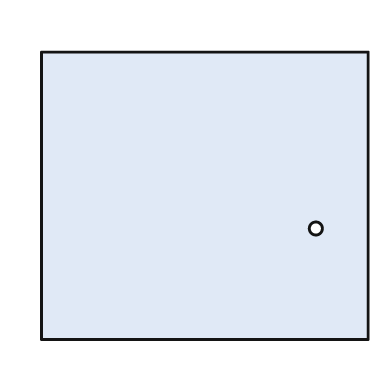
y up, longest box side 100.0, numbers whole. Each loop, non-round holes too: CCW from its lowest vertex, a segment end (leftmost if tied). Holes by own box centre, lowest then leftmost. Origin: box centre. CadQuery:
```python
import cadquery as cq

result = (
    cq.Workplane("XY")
    .moveTo(-50.0, -44.0)
    .lineTo(50.0, -44.0)
    .lineTo(50.0, 44.0)
    .lineTo(-50.0, 44.0)
    .close()
    .moveTo(34.0, -10.0)
    .circle(2.0)
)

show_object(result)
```